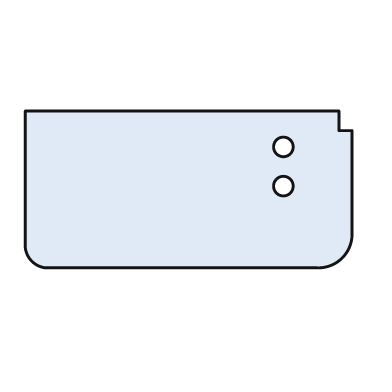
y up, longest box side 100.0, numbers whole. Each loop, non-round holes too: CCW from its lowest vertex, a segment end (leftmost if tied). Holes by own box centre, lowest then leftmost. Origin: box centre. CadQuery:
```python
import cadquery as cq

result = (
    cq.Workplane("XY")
    .moveTo(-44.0, -24.0)
    .lineTo(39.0, -24.0)
    .threePointArc((47.0, -21.0), (50.0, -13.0))
    .lineTo(50.0, 18.0)
    .lineTo(46.0, 18.0)
    .lineTo(46.0, 24.0)
    .lineTo(-50.0, 24.0)
    .lineTo(-50.0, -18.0)
    .threePointArc((-48.0, -22.0), (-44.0, -24.0))
    .close()
    .moveTo(29.0, 1.0)
    .circle(3.0)
    .moveTo(29.0, 13.0)
    .circle(3.0)
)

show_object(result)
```